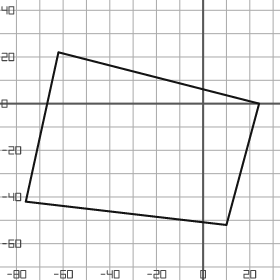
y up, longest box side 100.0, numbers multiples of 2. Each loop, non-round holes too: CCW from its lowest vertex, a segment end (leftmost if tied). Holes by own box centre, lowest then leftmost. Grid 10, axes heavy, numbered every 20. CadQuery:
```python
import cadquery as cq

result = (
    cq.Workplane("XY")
    .moveTo(10.0, -52.0)
    .lineTo(24.0, 0.0)
    .lineTo(-62.0, 22.0)
    .lineTo(-76.0, -42.0)
    .close()
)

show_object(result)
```